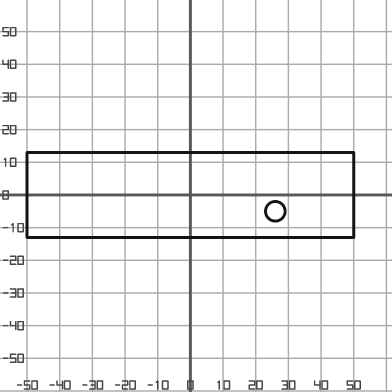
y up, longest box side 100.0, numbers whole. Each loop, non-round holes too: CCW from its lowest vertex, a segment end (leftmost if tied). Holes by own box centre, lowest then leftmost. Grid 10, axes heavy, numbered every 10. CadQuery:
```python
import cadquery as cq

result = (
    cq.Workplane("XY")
    .moveTo(-50.0, -13.0)
    .lineTo(50.0, -13.0)
    .lineTo(50.0, 13.0)
    .lineTo(-50.0, 13.0)
    .close()
    .moveTo(26.0, -5.0)
    .circle(3.0)
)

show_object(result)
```